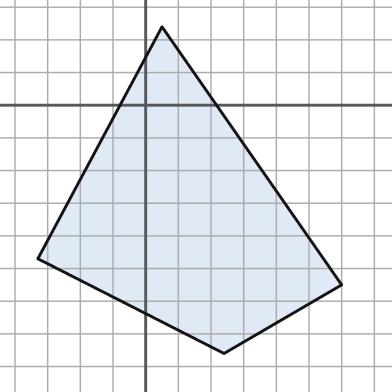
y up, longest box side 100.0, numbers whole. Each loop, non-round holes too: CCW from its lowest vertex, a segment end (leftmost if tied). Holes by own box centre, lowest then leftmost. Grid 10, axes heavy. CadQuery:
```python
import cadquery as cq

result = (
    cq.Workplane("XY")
    .moveTo(24.0, -76.0)
    .lineTo(60.0, -55.0)
    .lineTo(5.0, 24.0)
    .lineTo(-33.0, -47.0)
    .close()
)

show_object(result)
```